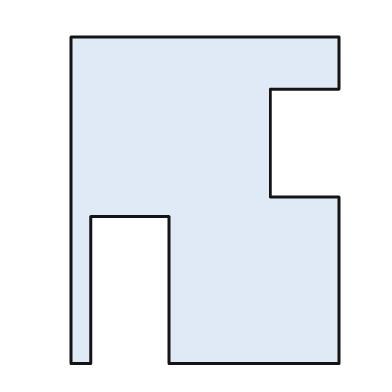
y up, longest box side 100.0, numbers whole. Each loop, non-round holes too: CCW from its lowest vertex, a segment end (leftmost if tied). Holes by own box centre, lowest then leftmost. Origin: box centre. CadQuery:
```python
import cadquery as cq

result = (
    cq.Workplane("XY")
    .moveTo(-41.0, -50.0)
    .lineTo(-35.0, -50.0)
    .lineTo(-35.0, -5.0)
    .lineTo(-11.0, -5.0)
    .lineTo(-11.0, -50.0)
    .lineTo(41.0, -50.0)
    .lineTo(41.0, 1.0)
    .lineTo(20.0, 1.0)
    .lineTo(20.0, 34.0)
    .lineTo(41.0, 34.0)
    .lineTo(41.0, 50.0)
    .lineTo(-41.0, 50.0)
    .close()
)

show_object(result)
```